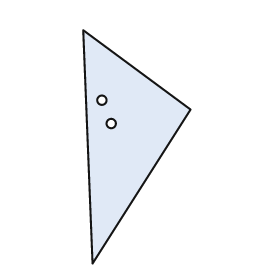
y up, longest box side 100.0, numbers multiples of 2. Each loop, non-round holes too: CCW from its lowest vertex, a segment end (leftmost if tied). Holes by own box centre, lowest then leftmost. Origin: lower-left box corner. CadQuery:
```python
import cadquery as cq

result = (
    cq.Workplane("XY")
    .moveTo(4.0, 0.0)
    .lineTo(46.0, 66.0)
    .lineTo(0.0, 100.0)
    .close()
    .moveTo(12.0, 60.0)
    .circle(2.0)
    .moveTo(8.0, 70.0)
    .circle(2.0)
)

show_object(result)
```